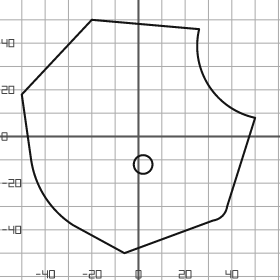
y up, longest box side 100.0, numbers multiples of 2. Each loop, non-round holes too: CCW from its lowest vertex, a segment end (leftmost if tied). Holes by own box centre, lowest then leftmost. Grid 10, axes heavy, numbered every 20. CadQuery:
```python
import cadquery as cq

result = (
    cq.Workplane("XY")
    .moveTo(-6.0, -50.0)
    .lineTo(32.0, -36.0)
    .threePointArc((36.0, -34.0), (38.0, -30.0))
    .lineTo(50.0, 8.0)
    .threePointArc((30.0, 22.0), (26.0, 46.0))
    .lineTo(-20.0, 50.0)
    .lineTo(-50.0, 18.0)
    .lineTo(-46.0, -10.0)
    .threePointArc((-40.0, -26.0), (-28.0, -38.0))
    .close()
    .moveTo(2.0, -12.0)
    .circle(4.0)
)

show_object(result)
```